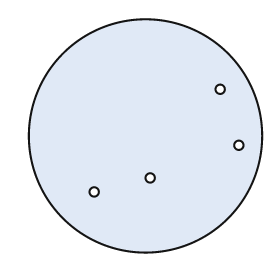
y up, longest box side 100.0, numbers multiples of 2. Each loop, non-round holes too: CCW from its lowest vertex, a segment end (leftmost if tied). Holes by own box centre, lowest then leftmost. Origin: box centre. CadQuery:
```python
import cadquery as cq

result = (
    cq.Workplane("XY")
    .moveTo(0.0, 0.0)
    .circle(50.0)
    .moveTo(-22.0, -24.0)
    .circle(2.0)
    .moveTo(2.0, -18.0)
    .circle(2.0)
    .moveTo(40.0, -4.0)
    .circle(2.0)
    .moveTo(32.0, 20.0)
    .circle(2.0)
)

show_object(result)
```